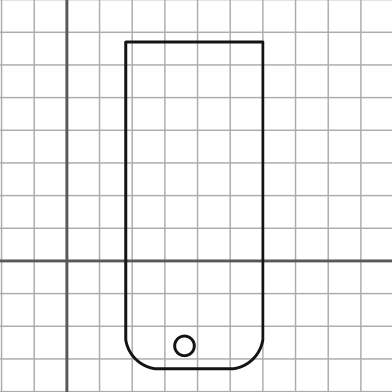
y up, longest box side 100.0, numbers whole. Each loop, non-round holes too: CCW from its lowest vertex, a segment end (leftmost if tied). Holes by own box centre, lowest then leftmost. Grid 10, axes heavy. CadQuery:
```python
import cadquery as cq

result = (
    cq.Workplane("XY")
    .moveTo(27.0, -33.0)
    .lineTo(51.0, -33.0)
    .threePointArc((57.0, -30.0), (60.0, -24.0))
    .lineTo(60.0, 67.0)
    .lineTo(18.0, 67.0)
    .lineTo(18.0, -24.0)
    .threePointArc((21.0, -30.0), (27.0, -33.0))
    .close()
    .moveTo(36.0, -26.0)
    .circle(3.0)
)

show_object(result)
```